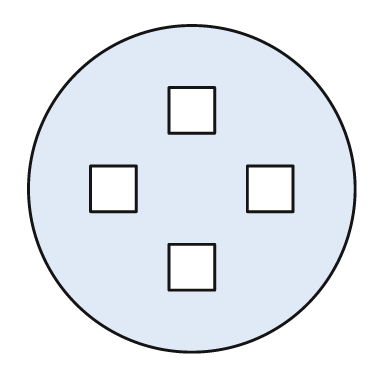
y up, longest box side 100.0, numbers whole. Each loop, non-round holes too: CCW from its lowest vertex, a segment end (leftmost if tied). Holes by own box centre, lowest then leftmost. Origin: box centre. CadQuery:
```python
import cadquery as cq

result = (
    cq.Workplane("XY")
    .moveTo(0.0, 0.0)
    .circle(50.0)
    .moveTo(-7.0, -31.0)
    .lineTo(7.0, -31.0)
    .lineTo(7.0, -17.0)
    .lineTo(-7.0, -17.0)
    .close()
    .moveTo(-31.0, -7.0)
    .lineTo(-17.0, -7.0)
    .lineTo(-17.0, 7.0)
    .lineTo(-31.0, 7.0)
    .close()
    .moveTo(17.0, -7.0)
    .lineTo(31.0, -7.0)
    .lineTo(31.0, 7.0)
    .lineTo(17.0, 7.0)
    .close()
    .moveTo(-7.0, 17.0)
    .lineTo(7.0, 17.0)
    .lineTo(7.0, 31.0)
    .lineTo(-7.0, 31.0)
    .close()
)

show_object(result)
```